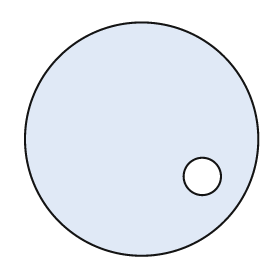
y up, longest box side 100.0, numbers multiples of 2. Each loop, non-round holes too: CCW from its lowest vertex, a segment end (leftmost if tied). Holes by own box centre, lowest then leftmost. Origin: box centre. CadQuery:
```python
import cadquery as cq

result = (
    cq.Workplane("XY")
    .moveTo(0.0, 0.0)
    .circle(50.0)
    .moveTo(26.0, -16.0)
    .circle(8.0)
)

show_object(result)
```